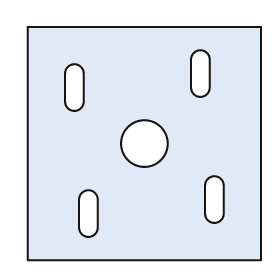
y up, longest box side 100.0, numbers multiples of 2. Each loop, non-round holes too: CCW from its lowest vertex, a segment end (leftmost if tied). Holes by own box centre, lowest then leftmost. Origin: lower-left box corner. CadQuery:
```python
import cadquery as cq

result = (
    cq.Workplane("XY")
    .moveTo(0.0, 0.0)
    .lineTo(100.0, 0.0)
    .lineTo(100.0, 100.0)
    .lineTo(0.0, 100.0)
    .close()
    .moveTo(22.0, 14.0)
    .threePointArc((26.0, 10.0), (30.0, 14.0))
    .lineTo(30.0, 26.0)
    .threePointArc((26.0, 30.0), (22.0, 26.0))
    .close()
    .moveTo(76.0, 20.0)
    .threePointArc((80.0, 16.0), (84.0, 20.0))
    .lineTo(84.0, 32.0)
    .threePointArc((80.0, 36.0), (76.0, 32.0))
    .close()
    .moveTo(50.0, 50.0)
    .circle(10.0)
    .moveTo(16.0, 68.0)
    .threePointArc((20.0, 64.0), (24.0, 68.0))
    .lineTo(24.0, 80.0)
    .threePointArc((20.0, 84.0), (16.0, 80.0))
    .close()
    .moveTo(70.0, 74.0)
    .threePointArc((74.0, 70.0), (78.0, 74.0))
    .lineTo(78.0, 86.0)
    .threePointArc((74.0, 90.0), (70.0, 86.0))
    .close()
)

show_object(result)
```